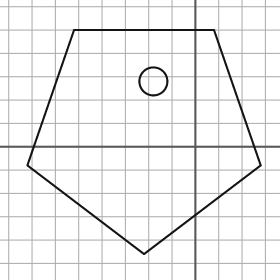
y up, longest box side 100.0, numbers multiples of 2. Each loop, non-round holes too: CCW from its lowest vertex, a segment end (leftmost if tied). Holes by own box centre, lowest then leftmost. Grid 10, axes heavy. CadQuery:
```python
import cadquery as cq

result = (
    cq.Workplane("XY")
    .moveTo(-22.0, -46.0)
    .lineTo(28.0, -8.0)
    .lineTo(8.0, 50.0)
    .lineTo(-52.0, 50.0)
    .lineTo(-72.0, -8.0)
    .close()
    .moveTo(-18.0, 28.0)
    .circle(6.0)
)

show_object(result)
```